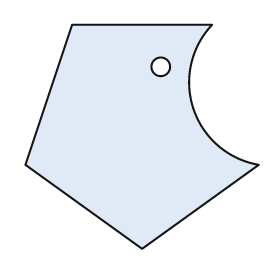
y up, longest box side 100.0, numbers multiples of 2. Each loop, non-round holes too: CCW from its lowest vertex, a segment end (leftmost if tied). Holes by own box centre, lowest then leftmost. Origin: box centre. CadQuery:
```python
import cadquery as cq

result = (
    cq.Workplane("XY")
    .moveTo(0.0, -48.0)
    .lineTo(50.0, -12.0)
    .threePointArc((22.0, 12.0), (30.0, 48.0))
    .lineTo(-30.0, 48.0)
    .lineTo(-50.0, -12.0)
    .close()
    .moveTo(8.0, 30.0)
    .circle(4.0)
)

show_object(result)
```